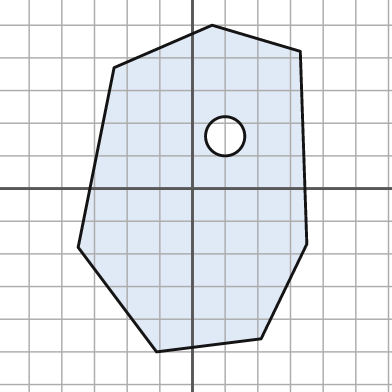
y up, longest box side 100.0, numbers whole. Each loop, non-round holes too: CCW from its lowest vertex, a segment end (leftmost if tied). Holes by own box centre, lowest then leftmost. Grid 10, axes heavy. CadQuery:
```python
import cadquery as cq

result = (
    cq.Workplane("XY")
    .moveTo(-11.0, -50.0)
    .lineTo(21.0, -46.0)
    .lineTo(35.0, -17.0)
    .lineTo(33.0, 42.0)
    .lineTo(6.0, 50.0)
    .lineTo(-24.0, 37.0)
    .lineTo(-35.0, -18.0)
    .close()
    .moveTo(10.0, 16.0)
    .circle(6.0)
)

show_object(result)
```